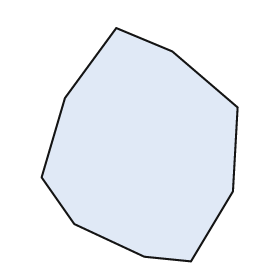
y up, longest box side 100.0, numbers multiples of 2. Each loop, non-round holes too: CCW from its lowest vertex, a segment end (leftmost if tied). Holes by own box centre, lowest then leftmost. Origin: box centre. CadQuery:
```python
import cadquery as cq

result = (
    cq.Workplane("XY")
    .moveTo(22.0, -50.0)
    .lineTo(40.0, -20.0)
    .lineTo(42.0, 16.0)
    .lineTo(14.0, 40.0)
    .lineTo(-10.0, 50.0)
    .lineTo(-32.0, 20.0)
    .lineTo(-42.0, -14.0)
    .lineTo(-28.0, -34.0)
    .lineTo(2.0, -48.0)
    .close()
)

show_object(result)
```